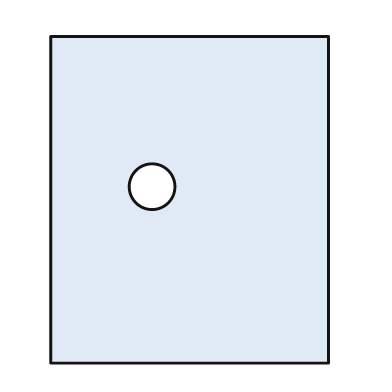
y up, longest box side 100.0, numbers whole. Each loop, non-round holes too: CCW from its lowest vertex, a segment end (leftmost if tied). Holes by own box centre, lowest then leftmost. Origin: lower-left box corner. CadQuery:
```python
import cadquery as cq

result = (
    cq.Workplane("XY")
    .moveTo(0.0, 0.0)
    .lineTo(85.0, 0.0)
    .lineTo(85.0, 100.0)
    .lineTo(0.0, 100.0)
    .close()
    .moveTo(31.0, 54.0)
    .circle(7.0)
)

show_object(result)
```